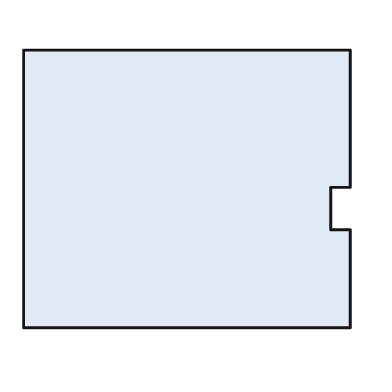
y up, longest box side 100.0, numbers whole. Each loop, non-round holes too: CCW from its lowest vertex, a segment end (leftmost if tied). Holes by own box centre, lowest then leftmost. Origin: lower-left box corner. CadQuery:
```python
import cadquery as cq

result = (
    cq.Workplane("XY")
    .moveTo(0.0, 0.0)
    .lineTo(100.0, 0.0)
    .lineTo(100.0, 30.0)
    .lineTo(94.0, 30.0)
    .lineTo(94.0, 43.0)
    .lineTo(100.0, 43.0)
    .lineTo(100.0, 85.0)
    .lineTo(0.0, 85.0)
    .close()
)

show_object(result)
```